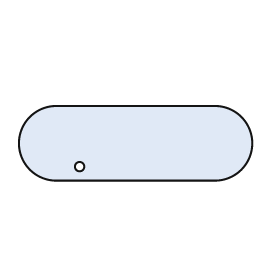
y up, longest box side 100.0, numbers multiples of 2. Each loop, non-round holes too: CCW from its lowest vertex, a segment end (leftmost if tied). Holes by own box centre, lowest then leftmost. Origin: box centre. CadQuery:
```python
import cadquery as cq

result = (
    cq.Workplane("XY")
    .moveTo(-34.0, -16.0)
    .lineTo(34.0, -16.0)
    .threePointArc((50.0, 0.0), (34.0, 16.0))
    .lineTo(-34.0, 16.0)
    .threePointArc((-50.0, 0.0), (-34.0, -16.0))
    .close()
    .moveTo(-24.0, -10.0)
    .circle(2.0)
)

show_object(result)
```